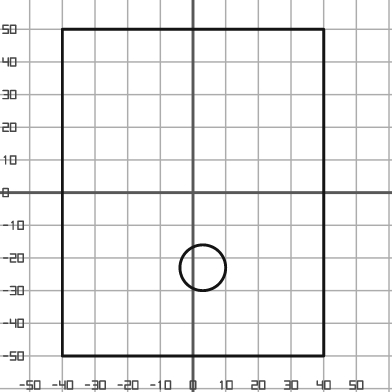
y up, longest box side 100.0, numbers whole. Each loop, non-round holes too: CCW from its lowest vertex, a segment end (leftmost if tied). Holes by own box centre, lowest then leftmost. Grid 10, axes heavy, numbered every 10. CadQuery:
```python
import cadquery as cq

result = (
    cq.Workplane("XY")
    .moveTo(-40.0, -50.0)
    .lineTo(40.0, -50.0)
    .lineTo(40.0, 50.0)
    .lineTo(-40.0, 50.0)
    .close()
    .moveTo(3.0, -23.0)
    .circle(7.0)
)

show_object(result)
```